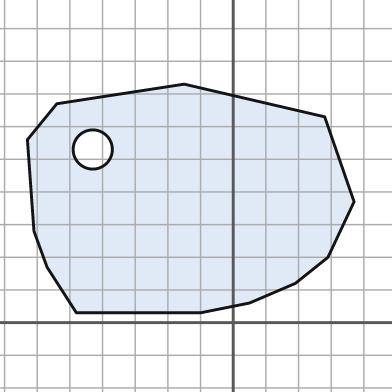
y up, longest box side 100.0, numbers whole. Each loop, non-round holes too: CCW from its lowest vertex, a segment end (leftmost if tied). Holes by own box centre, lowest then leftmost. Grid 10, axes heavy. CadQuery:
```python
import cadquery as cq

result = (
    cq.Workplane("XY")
    .moveTo(-48.0, 3.0)
    .lineTo(-10.0, 3.0)
    .lineTo(5.0, 6.0)
    .lineTo(19.0, 12.0)
    .lineTo(29.0, 20.0)
    .lineTo(37.0, 37.0)
    .lineTo(28.0, 63.0)
    .lineTo(-15.0, 73.0)
    .lineTo(-54.0, 67.0)
    .lineTo(-63.0, 56.0)
    .lineTo(-61.0, 28.0)
    .lineTo(-57.0, 17.0)
    .close()
    .moveTo(-43.0, 53.0)
    .circle(6.0)
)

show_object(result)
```